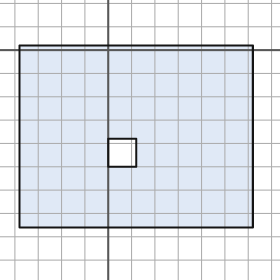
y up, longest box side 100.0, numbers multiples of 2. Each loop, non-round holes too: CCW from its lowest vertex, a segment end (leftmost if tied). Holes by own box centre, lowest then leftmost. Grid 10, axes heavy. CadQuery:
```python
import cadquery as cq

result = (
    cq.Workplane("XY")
    .moveTo(-38.0, -76.0)
    .lineTo(62.0, -76.0)
    .lineTo(62.0, 2.0)
    .lineTo(-38.0, 2.0)
    .close()
    .moveTo(0.0, -50.0)
    .lineTo(12.0, -50.0)
    .lineTo(12.0, -38.0)
    .lineTo(0.0, -38.0)
    .close()
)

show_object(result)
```